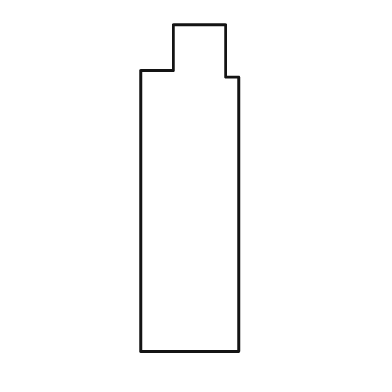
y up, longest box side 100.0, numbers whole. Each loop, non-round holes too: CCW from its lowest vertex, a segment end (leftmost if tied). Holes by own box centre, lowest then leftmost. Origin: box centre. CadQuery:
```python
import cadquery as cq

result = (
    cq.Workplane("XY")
    .moveTo(-15.0, -50.0)
    .lineTo(15.0, -50.0)
    .lineTo(15.0, 34.0)
    .lineTo(11.0, 34.0)
    .lineTo(11.0, 50.0)
    .lineTo(-5.0, 50.0)
    .lineTo(-5.0, 36.0)
    .lineTo(-15.0, 36.0)
    .close()
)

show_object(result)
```